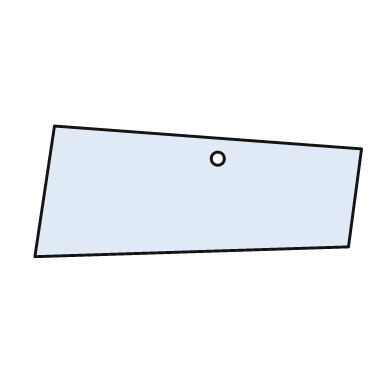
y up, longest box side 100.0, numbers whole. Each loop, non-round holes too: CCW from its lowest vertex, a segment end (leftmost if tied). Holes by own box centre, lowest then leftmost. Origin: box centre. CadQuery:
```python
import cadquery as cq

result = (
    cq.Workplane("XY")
    .moveTo(-50.0, -20.0)
    .lineTo(46.0, -17.0)
    .lineTo(50.0, 13.0)
    .lineTo(-44.0, 20.0)
    .close()
    .moveTo(6.0, 10.0)
    .circle(2.0)
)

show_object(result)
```